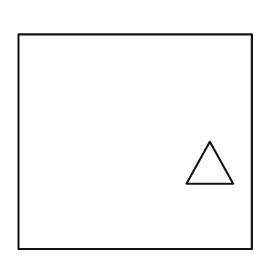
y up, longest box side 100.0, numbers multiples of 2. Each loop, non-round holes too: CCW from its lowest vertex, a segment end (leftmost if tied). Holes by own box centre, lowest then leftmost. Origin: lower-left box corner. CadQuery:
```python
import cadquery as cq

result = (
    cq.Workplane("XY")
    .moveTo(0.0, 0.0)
    .lineTo(100.0, 0.0)
    .lineTo(100.0, 92.0)
    .lineTo(0.0, 92.0)
    .close()
    .moveTo(72.0, 28.0)
    .lineTo(92.0, 28.0)
    .lineTo(82.0, 46.0)
    .close()
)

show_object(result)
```